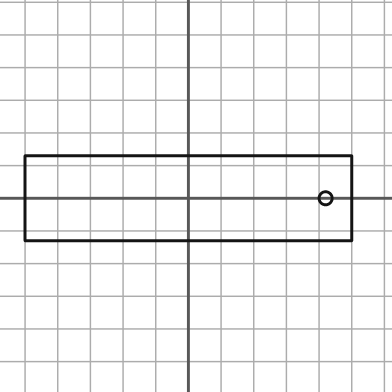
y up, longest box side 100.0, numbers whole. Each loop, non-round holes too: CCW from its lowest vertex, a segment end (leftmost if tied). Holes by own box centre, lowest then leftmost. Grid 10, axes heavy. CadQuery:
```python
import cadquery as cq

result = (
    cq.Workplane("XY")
    .moveTo(-50.0, -13.0)
    .lineTo(50.0, -13.0)
    .lineTo(50.0, 13.0)
    .lineTo(-50.0, 13.0)
    .close()
    .moveTo(42.0, 0.0)
    .circle(2.0)
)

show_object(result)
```